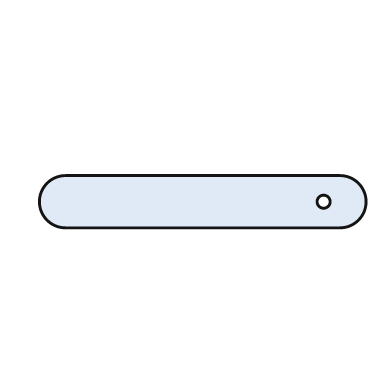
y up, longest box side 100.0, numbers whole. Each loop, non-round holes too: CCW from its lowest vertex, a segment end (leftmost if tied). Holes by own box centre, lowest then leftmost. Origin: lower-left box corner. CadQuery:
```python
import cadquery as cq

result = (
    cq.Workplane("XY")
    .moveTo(8.0, 0.0)
    .lineTo(92.0, 0.0)
    .threePointArc((100.0, 8.0), (92.0, 16.0))
    .lineTo(8.0, 16.0)
    .threePointArc((0.0, 8.0), (8.0, 0.0))
    .close()
    .moveTo(87.0, 8.0)
    .circle(2.0)
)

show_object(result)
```